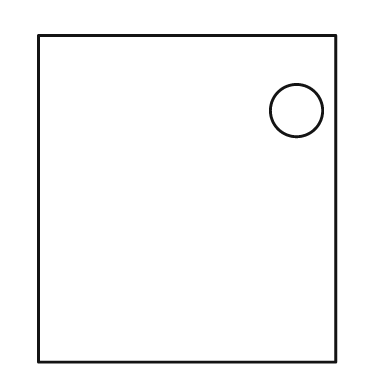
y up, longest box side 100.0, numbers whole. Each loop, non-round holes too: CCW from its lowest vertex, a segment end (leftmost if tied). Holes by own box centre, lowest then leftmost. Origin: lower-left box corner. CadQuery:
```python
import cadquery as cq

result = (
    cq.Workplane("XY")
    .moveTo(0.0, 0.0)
    .lineTo(91.0, 0.0)
    .lineTo(91.0, 100.0)
    .lineTo(0.0, 100.0)
    .close()
    .moveTo(79.0, 77.0)
    .circle(8.0)
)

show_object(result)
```